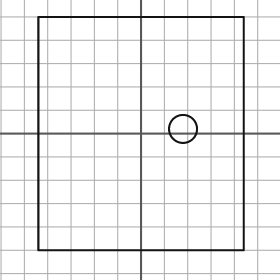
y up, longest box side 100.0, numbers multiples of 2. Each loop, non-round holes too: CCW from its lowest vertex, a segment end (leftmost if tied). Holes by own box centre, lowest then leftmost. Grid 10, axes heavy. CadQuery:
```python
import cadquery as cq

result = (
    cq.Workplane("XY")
    .moveTo(-44.0, -50.0)
    .lineTo(44.0, -50.0)
    .lineTo(44.0, 50.0)
    .lineTo(-44.0, 50.0)
    .close()
    .moveTo(18.0, 2.0)
    .circle(6.0)
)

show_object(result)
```